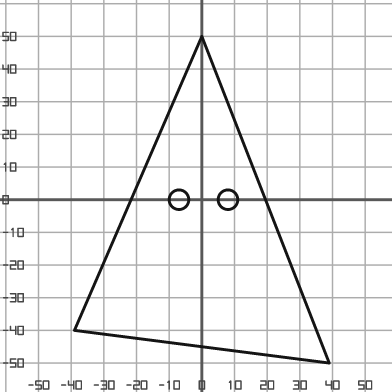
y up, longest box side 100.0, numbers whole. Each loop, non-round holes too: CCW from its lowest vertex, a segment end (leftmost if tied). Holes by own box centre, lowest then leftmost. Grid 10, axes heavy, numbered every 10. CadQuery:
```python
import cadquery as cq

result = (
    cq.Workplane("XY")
    .moveTo(39.0, -50.0)
    .lineTo(0.0, 50.0)
    .lineTo(-39.0, -40.0)
    .close()
    .moveTo(-7.0, 0.0)
    .circle(3.0)
    .moveTo(8.0, 0.0)
    .circle(3.0)
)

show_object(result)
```